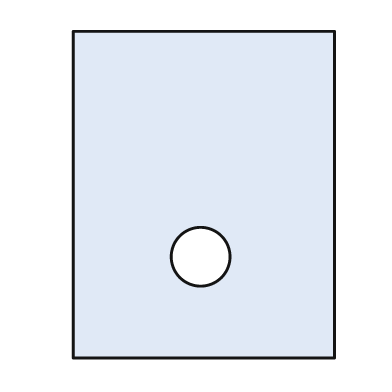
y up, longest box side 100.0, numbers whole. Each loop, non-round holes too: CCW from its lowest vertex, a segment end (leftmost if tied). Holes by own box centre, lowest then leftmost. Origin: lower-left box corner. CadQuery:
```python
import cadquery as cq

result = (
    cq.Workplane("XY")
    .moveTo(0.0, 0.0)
    .lineTo(80.0, 0.0)
    .lineTo(80.0, 100.0)
    .lineTo(0.0, 100.0)
    .close()
    .moveTo(39.0, 31.0)
    .circle(9.0)
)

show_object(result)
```